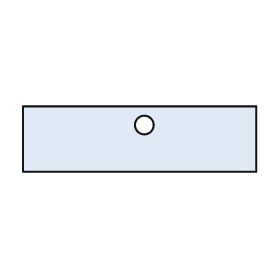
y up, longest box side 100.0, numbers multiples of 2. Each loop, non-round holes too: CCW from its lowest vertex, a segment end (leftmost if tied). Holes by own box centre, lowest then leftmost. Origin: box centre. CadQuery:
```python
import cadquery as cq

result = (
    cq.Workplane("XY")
    .moveTo(-50.0, -14.0)
    .lineTo(50.0, -14.0)
    .lineTo(50.0, 14.0)
    .lineTo(-50.0, 14.0)
    .close()
    .moveTo(2.0, 6.0)
    .circle(4.0)
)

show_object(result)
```